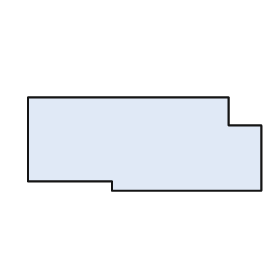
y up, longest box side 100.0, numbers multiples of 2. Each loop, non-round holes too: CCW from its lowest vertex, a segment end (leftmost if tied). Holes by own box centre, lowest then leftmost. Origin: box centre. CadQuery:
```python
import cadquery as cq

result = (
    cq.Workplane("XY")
    .moveTo(-14.0, -20.0)
    .lineTo(50.0, -20.0)
    .lineTo(50.0, 8.0)
    .lineTo(36.0, 8.0)
    .lineTo(36.0, 20.0)
    .lineTo(-50.0, 20.0)
    .lineTo(-50.0, -16.0)
    .lineTo(-14.0, -16.0)
    .close()
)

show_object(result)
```